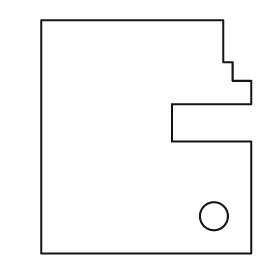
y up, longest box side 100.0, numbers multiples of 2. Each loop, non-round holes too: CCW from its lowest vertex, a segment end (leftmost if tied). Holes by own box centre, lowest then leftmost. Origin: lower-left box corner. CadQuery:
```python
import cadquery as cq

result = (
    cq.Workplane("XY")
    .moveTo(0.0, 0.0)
    .lineTo(90.0, 0.0)
    .lineTo(90.0, 48.0)
    .lineTo(56.0, 48.0)
    .lineTo(56.0, 64.0)
    .lineTo(90.0, 64.0)
    .lineTo(90.0, 74.0)
    .lineTo(82.0, 74.0)
    .lineTo(82.0, 82.0)
    .lineTo(78.0, 82.0)
    .lineTo(78.0, 100.0)
    .lineTo(0.0, 100.0)
    .close()
    .moveTo(74.0, 16.0)
    .circle(6.0)
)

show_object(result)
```